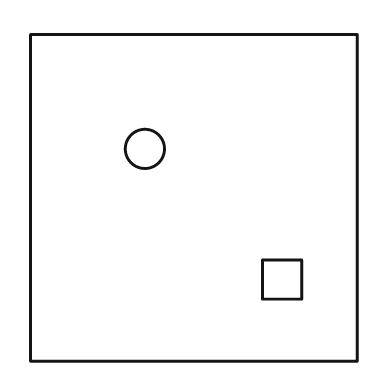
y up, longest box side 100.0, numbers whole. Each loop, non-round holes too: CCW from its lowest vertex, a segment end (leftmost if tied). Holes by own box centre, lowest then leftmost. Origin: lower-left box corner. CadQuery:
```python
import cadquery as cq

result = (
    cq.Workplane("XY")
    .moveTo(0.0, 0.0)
    .lineTo(100.0, 0.0)
    .lineTo(100.0, 100.0)
    .lineTo(0.0, 100.0)
    .close()
    .moveTo(71.0, 19.0)
    .lineTo(83.0, 19.0)
    .lineTo(83.0, 31.0)
    .lineTo(71.0, 31.0)
    .close()
    .moveTo(35.0, 65.0)
    .circle(6.0)
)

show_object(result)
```